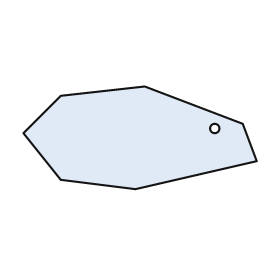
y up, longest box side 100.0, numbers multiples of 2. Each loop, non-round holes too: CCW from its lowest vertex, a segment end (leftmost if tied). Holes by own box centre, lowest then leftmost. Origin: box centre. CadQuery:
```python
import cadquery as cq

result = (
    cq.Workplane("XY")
    .moveTo(-2.0, -22.0)
    .lineTo(50.0, -10.0)
    .lineTo(44.0, 6.0)
    .lineTo(2.0, 22.0)
    .lineTo(-34.0, 18.0)
    .lineTo(-50.0, 2.0)
    .lineTo(-34.0, -18.0)
    .close()
    .moveTo(32.0, 4.0)
    .circle(2.0)
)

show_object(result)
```